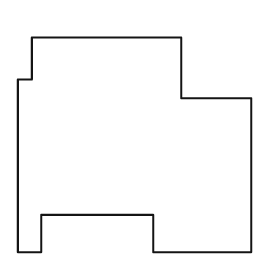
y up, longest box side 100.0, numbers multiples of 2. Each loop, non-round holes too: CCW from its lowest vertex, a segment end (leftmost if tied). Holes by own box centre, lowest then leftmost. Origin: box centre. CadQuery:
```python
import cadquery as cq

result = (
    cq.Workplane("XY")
    .moveTo(-50.0, -46.0)
    .lineTo(-40.0, -46.0)
    .lineTo(-40.0, -30.0)
    .lineTo(8.0, -30.0)
    .lineTo(8.0, -46.0)
    .lineTo(50.0, -46.0)
    .lineTo(50.0, 20.0)
    .lineTo(20.0, 20.0)
    .lineTo(20.0, 46.0)
    .lineTo(-44.0, 46.0)
    .lineTo(-44.0, 28.0)
    .lineTo(-50.0, 28.0)
    .close()
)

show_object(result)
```